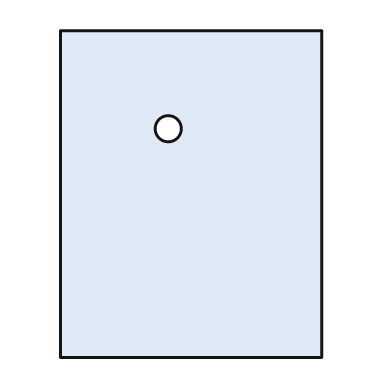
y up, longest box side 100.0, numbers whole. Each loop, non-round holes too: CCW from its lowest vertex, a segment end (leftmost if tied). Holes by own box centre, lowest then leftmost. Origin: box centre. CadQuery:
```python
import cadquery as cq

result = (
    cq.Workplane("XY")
    .moveTo(-40.0, -50.0)
    .lineTo(40.0, -50.0)
    .lineTo(40.0, 50.0)
    .lineTo(-40.0, 50.0)
    .close()
    .moveTo(-7.0, 20.0)
    .circle(4.0)
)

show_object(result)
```